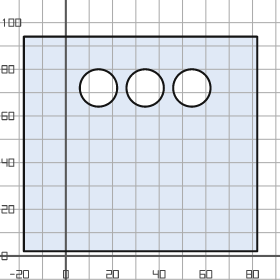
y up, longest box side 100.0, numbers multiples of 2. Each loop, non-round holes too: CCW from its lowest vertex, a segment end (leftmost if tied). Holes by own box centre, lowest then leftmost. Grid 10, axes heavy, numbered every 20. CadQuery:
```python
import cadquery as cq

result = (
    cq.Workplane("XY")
    .moveTo(-18.0, 2.0)
    .lineTo(82.0, 2.0)
    .lineTo(82.0, 94.0)
    .lineTo(-18.0, 94.0)
    .close()
    .moveTo(14.0, 72.0)
    .circle(8.0)
    .moveTo(34.0, 72.0)
    .circle(8.0)
    .moveTo(54.0, 72.0)
    .circle(8.0)
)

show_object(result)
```